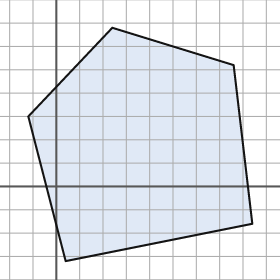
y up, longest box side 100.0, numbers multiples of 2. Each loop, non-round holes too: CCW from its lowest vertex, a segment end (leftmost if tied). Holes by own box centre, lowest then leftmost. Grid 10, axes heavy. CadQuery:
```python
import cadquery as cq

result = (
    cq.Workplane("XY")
    .moveTo(4.0, -32.0)
    .lineTo(84.0, -16.0)
    .lineTo(76.0, 52.0)
    .lineTo(24.0, 68.0)
    .lineTo(-12.0, 30.0)
    .close()
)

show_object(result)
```